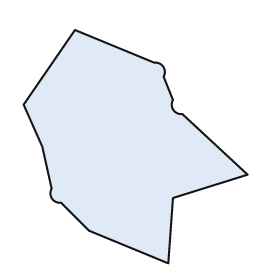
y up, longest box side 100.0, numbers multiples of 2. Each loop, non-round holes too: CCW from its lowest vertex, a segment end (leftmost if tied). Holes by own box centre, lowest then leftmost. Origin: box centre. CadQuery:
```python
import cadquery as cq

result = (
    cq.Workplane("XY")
    .moveTo(14.0, -50.0)
    .lineTo(16.0, -22.0)
    .lineTo(48.0, -12.0)
    .lineTo(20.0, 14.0)
    .threePointArc((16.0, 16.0), (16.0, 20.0))
    .lineTo(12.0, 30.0)
    .threePointArc((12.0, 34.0), (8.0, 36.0))
    .lineTo(-26.0, 50.0)
    .lineTo(-48.0, 18.0)
    .lineTo(-40.0, 0.0)
    .lineTo(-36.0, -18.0)
    .threePointArc((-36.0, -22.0), (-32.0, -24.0))
    .lineTo(-20.0, -36.0)
    .close()
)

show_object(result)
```